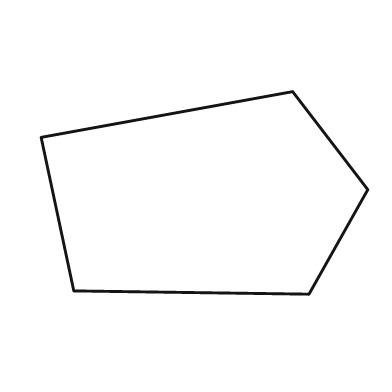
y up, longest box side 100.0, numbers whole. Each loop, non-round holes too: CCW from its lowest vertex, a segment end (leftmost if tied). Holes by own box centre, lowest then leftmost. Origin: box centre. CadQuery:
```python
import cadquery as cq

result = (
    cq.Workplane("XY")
    .moveTo(32.0, -31.0)
    .lineTo(50.0, 1.0)
    .lineTo(27.0, 31.0)
    .lineTo(-50.0, 17.0)
    .lineTo(-40.0, -30.0)
    .close()
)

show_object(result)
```